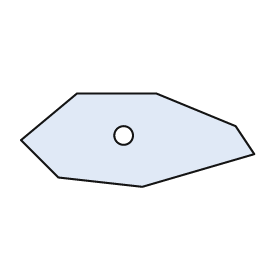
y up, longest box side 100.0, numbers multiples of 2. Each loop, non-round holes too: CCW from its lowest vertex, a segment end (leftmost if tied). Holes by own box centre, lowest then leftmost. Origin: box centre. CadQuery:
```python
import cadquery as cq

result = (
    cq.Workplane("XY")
    .moveTo(2.0, -20.0)
    .lineTo(50.0, -6.0)
    .lineTo(42.0, 6.0)
    .lineTo(8.0, 20.0)
    .lineTo(-26.0, 20.0)
    .lineTo(-50.0, 0.0)
    .lineTo(-34.0, -16.0)
    .close()
    .moveTo(-6.0, 2.0)
    .circle(4.0)
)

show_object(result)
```